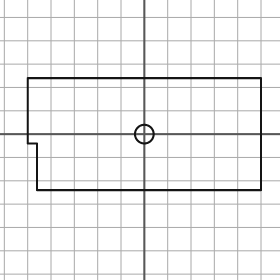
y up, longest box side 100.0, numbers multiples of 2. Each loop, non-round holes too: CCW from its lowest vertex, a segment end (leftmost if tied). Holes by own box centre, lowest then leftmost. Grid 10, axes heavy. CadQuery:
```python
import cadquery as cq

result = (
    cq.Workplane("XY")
    .moveTo(-46.0, -24.0)
    .lineTo(50.0, -24.0)
    .lineTo(50.0, 24.0)
    .lineTo(-50.0, 24.0)
    .lineTo(-50.0, -4.0)
    .lineTo(-46.0, -4.0)
    .close()
    .moveTo(0.0, 0.0)
    .circle(4.0)
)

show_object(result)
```